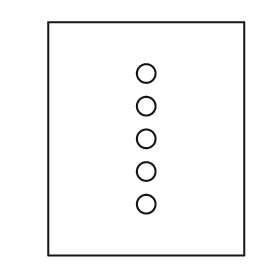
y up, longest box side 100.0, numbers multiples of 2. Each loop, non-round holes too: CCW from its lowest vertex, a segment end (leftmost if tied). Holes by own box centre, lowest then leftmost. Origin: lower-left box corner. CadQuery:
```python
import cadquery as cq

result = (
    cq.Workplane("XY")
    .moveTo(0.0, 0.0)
    .lineTo(84.0, 0.0)
    .lineTo(84.0, 100.0)
    .lineTo(0.0, 100.0)
    .close()
    .moveTo(42.0, 22.0)
    .circle(4.0)
    .moveTo(42.0, 36.0)
    .circle(4.0)
    .moveTo(42.0, 50.0)
    .circle(4.0)
    .moveTo(42.0, 64.0)
    .circle(4.0)
    .moveTo(42.0, 78.0)
    .circle(4.0)
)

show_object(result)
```